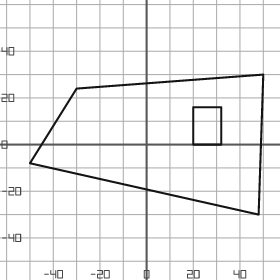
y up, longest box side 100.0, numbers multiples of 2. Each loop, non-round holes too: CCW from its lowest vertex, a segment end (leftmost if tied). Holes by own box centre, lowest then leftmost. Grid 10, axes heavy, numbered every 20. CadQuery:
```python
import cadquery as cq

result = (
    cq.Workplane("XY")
    .moveTo(48.0, -30.0)
    .lineTo(50.0, 30.0)
    .lineTo(-30.0, 24.0)
    .lineTo(-50.0, -8.0)
    .close()
    .moveTo(20.0, 0.0)
    .lineTo(32.0, 0.0)
    .lineTo(32.0, 16.0)
    .lineTo(20.0, 16.0)
    .close()
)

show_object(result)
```